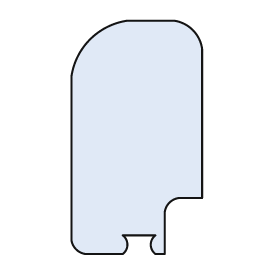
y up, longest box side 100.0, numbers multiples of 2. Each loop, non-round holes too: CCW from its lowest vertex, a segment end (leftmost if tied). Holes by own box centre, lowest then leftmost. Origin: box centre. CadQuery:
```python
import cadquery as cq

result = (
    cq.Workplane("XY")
    .moveTo(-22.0, -50.0)
    .lineTo(-6.0, -50.0)
    .threePointArc((-4.0, -46.0), (-6.0, -42.0))
    .lineTo(8.0, -42.0)
    .threePointArc((6.0, -46.0), (8.0, -50.0))
    .lineTo(12.0, -50.0)
    .lineTo(12.0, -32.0)
    .threePointArc((14.0, -28.0), (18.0, -26.0))
    .lineTo(28.0, -26.0)
    .lineTo(28.0, 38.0)
    .threePointArc((24.0, 46.0), (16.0, 50.0))
    .lineTo(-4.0, 50.0)
    .threePointArc((-20.0, 42.0), (-28.0, 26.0))
    .lineTo(-28.0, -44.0)
    .threePointArc((-26.0, -48.0), (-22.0, -50.0))
    .close()
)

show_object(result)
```